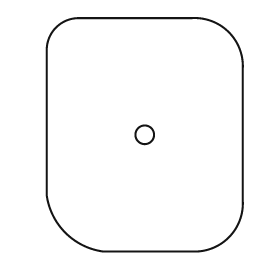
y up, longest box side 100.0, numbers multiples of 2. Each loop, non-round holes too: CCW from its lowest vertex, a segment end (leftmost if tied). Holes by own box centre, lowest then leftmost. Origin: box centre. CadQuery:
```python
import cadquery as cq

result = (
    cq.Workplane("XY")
    .moveTo(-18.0, -50.0)
    .lineTo(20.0, -50.0)
    .threePointArc((36.0, -44.0), (42.0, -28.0))
    .lineTo(42.0, 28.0)
    .threePointArc((36.0, 44.0), (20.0, 50.0))
    .lineTo(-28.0, 50.0)
    .threePointArc((-38.0, 46.0), (-42.0, 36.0))
    .lineTo(-42.0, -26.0)
    .threePointArc((-34.0, -42.0), (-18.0, -50.0))
    .close()
    .moveTo(0.0, 0.0)
    .circle(4.0)
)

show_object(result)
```